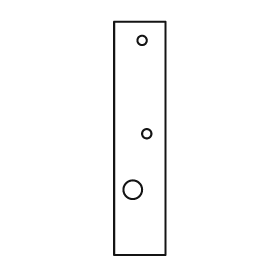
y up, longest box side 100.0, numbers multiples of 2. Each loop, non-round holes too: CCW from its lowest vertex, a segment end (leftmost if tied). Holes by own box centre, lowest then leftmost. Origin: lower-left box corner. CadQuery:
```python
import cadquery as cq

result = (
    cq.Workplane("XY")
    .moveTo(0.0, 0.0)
    .lineTo(22.0, 0.0)
    .lineTo(22.0, 100.0)
    .lineTo(0.0, 100.0)
    .close()
    .moveTo(8.0, 28.0)
    .circle(4.0)
    .moveTo(14.0, 52.0)
    .circle(2.0)
    .moveTo(12.0, 92.0)
    .circle(2.0)
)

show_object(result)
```